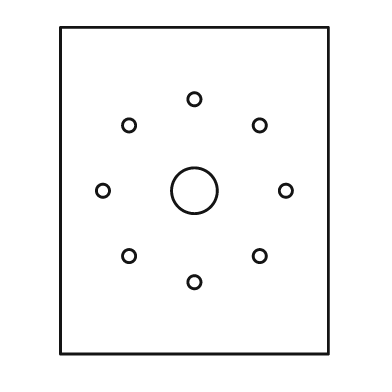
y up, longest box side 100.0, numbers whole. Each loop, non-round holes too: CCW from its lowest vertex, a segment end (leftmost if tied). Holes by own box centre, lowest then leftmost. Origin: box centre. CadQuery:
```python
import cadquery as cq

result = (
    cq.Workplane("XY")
    .moveTo(-41.0, -50.0)
    .lineTo(41.0, -50.0)
    .lineTo(41.0, 50.0)
    .lineTo(-41.0, 50.0)
    .close()
    .moveTo(0.0, -28.0)
    .circle(2.0)
    .moveTo(-20.0, -20.0)
    .circle(2.0)
    .moveTo(20.0, -20.0)
    .circle(2.0)
    .moveTo(-28.0, 0.0)
    .circle(2.0)
    .moveTo(0.0, 0.0)
    .circle(7.0)
    .moveTo(28.0, 0.0)
    .circle(2.0)
    .moveTo(-20.0, 20.0)
    .circle(2.0)
    .moveTo(20.0, 20.0)
    .circle(2.0)
    .moveTo(0.0, 28.0)
    .circle(2.0)
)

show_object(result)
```